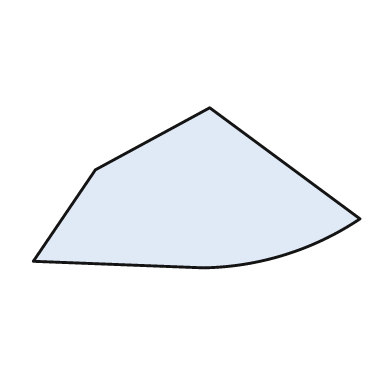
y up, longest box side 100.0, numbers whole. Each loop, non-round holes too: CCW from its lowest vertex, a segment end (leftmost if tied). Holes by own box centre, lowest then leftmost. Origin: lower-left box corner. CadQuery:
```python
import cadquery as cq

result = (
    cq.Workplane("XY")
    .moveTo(52.0, 0.0)
    .threePointArc((77.0, 4.0), (100.0, 15.0))
    .lineTo(54.0, 49.0)
    .lineTo(19.0, 30.0)
    .lineTo(0.0, 2.0)
    .close()
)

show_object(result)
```